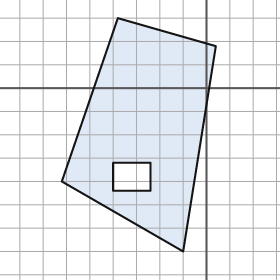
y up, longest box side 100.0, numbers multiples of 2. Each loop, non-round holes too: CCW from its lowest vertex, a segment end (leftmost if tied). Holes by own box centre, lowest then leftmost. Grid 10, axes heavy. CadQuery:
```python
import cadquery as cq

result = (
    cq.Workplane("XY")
    .moveTo(-10.0, -70.0)
    .lineTo(4.0, 18.0)
    .lineTo(-38.0, 30.0)
    .lineTo(-62.0, -40.0)
    .close()
    .moveTo(-40.0, -44.0)
    .lineTo(-24.0, -44.0)
    .lineTo(-24.0, -32.0)
    .lineTo(-40.0, -32.0)
    .close()
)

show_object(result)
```